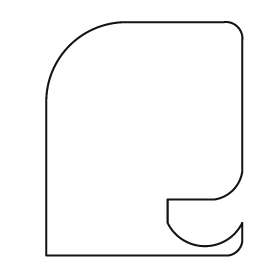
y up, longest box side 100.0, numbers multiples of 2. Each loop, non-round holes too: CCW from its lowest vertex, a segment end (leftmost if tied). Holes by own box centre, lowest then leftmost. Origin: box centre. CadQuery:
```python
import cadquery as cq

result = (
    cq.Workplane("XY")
    .moveTo(-42.0, -50.0)
    .lineTo(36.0, -50.0)
    .threePointArc((40.0, -48.0), (42.0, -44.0))
    .lineTo(42.0, -36.0)
    .threePointArc((26.0, -46.0), (10.0, -36.0))
    .lineTo(10.0, -26.0)
    .lineTo(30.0, -26.0)
    .threePointArc((38.0, -22.0), (42.0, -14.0))
    .lineTo(42.0, 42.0)
    .threePointArc((40.0, 48.0), (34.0, 50.0))
    .lineTo(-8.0, 50.0)
    .threePointArc((-32.0, 40.0), (-42.0, 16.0))
    .close()
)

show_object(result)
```